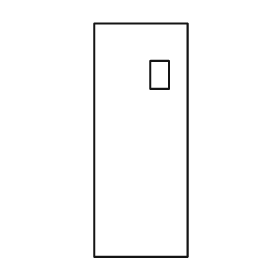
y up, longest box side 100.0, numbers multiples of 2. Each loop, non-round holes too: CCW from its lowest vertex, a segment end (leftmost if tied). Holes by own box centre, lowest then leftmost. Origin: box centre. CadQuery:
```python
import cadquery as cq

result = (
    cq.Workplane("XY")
    .moveTo(-20.0, -50.0)
    .lineTo(20.0, -50.0)
    .lineTo(20.0, 50.0)
    .lineTo(-20.0, 50.0)
    .close()
    .moveTo(4.0, 22.0)
    .lineTo(12.0, 22.0)
    .lineTo(12.0, 34.0)
    .lineTo(4.0, 34.0)
    .close()
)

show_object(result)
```